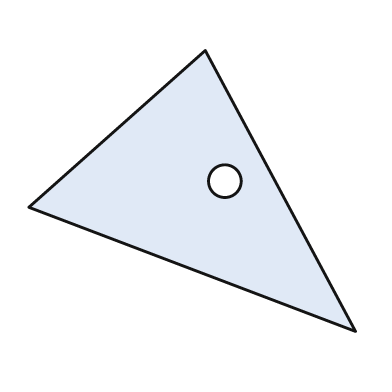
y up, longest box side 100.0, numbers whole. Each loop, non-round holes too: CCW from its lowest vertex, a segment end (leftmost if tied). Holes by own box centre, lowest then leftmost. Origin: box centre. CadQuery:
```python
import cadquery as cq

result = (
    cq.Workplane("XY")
    .moveTo(50.0, -43.0)
    .lineTo(4.0, 43.0)
    .lineTo(-50.0, -5.0)
    .close()
    .moveTo(10.0, 3.0)
    .circle(5.0)
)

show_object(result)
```